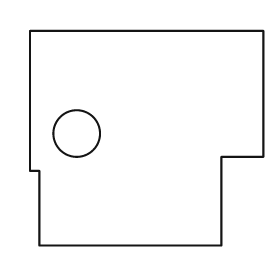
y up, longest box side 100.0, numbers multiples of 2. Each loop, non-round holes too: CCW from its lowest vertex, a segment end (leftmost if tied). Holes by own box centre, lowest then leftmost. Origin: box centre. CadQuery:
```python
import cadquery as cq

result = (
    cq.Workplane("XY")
    .moveTo(-46.0, -46.0)
    .lineTo(32.0, -46.0)
    .lineTo(32.0, -8.0)
    .lineTo(50.0, -8.0)
    .lineTo(50.0, 46.0)
    .lineTo(-50.0, 46.0)
    .lineTo(-50.0, -14.0)
    .lineTo(-46.0, -14.0)
    .close()
    .moveTo(-30.0, 2.0)
    .circle(10.0)
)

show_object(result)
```